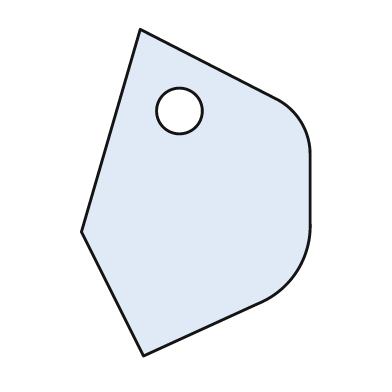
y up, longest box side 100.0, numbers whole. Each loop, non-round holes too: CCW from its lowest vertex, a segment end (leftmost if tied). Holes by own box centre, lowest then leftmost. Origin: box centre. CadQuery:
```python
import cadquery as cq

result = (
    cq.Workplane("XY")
    .moveTo(-16.0, -50.0)
    .lineTo(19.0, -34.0)
    .threePointArc((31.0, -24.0), (35.0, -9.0))
    .lineTo(35.0, 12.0)
    .threePointArc((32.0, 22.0), (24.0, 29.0))
    .lineTo(-17.0, 50.0)
    .lineTo(-35.0, -12.0)
    .close()
    .moveTo(-5.0, 25.0)
    .circle(7.0)
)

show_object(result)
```